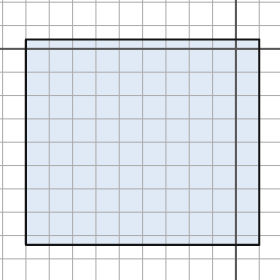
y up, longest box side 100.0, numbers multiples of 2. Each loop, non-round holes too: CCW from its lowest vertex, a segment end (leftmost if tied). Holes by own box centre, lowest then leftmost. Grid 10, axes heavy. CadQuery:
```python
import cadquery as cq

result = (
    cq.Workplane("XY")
    .moveTo(-90.0, -84.0)
    .lineTo(10.0, -84.0)
    .lineTo(10.0, 4.0)
    .lineTo(-90.0, 4.0)
    .close()
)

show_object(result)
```